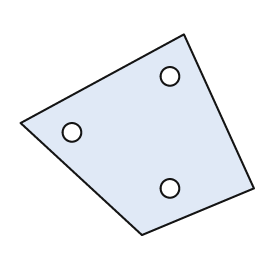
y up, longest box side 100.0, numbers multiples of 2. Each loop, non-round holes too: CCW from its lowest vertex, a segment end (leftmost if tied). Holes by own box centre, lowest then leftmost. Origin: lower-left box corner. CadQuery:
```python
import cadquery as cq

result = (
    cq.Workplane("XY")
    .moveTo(52.0, 0.0)
    .lineTo(100.0, 20.0)
    .lineTo(70.0, 86.0)
    .lineTo(0.0, 48.0)
    .close()
    .moveTo(64.0, 20.0)
    .circle(4.0)
    .moveTo(22.0, 44.0)
    .circle(4.0)
    .moveTo(64.0, 68.0)
    .circle(4.0)
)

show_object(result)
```